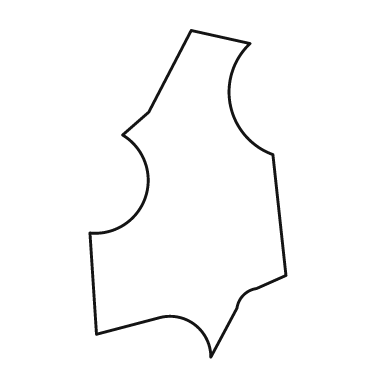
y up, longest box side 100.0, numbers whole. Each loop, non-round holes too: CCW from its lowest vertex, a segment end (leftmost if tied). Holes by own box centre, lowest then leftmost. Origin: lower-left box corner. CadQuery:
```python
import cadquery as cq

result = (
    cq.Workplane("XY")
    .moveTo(37.0, 0.0)
    .lineTo(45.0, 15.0)
    .threePointArc((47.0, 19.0), (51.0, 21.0))
    .lineTo(60.0, 25.0)
    .lineTo(56.0, 62.0)
    .threePointArc((43.0, 77.0), (49.0, 96.0))
    .lineTo(31.0, 100.0)
    .lineTo(18.0, 75.0)
    .lineTo(10.0, 68.0)
    .threePointArc((17.0, 49.0), (0.0, 38.0))
    .lineTo(2.0, 7.0)
    .lineTo(21.0, 12.0)
    .threePointArc((32.0, 10.0), (37.0, 0.0))
    .close()
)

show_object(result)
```